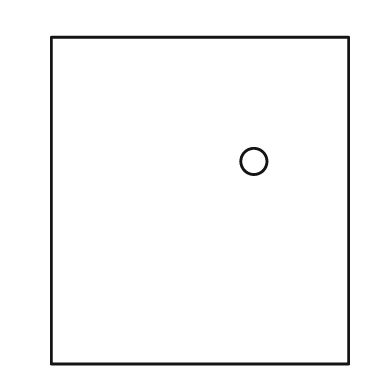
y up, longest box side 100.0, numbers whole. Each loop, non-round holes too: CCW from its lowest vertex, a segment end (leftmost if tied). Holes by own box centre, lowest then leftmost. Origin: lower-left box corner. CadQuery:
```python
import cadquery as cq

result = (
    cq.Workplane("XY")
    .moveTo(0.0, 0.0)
    .lineTo(91.0, 0.0)
    .lineTo(91.0, 100.0)
    .lineTo(0.0, 100.0)
    .close()
    .moveTo(62.0, 62.0)
    .circle(4.0)
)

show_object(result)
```